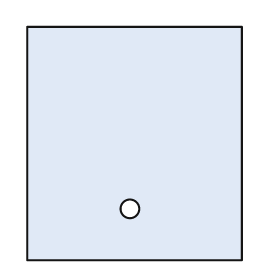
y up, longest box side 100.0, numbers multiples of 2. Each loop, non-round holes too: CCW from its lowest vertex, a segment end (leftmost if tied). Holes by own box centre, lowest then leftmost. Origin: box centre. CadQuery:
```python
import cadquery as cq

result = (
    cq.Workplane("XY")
    .moveTo(-46.0, -50.0)
    .lineTo(46.0, -50.0)
    .lineTo(46.0, 50.0)
    .lineTo(-46.0, 50.0)
    .close()
    .moveTo(-2.0, -28.0)
    .circle(4.0)
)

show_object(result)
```